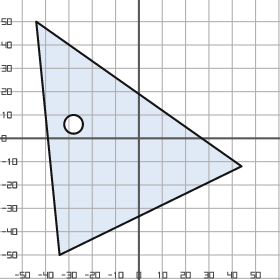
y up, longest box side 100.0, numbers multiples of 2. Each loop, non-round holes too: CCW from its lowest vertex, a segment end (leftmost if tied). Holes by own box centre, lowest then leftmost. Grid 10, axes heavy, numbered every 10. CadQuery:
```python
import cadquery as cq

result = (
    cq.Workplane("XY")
    .moveTo(-34.0, -50.0)
    .lineTo(44.0, -12.0)
    .lineTo(-44.0, 50.0)
    .close()
    .moveTo(-28.0, 6.0)
    .circle(4.0)
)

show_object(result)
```